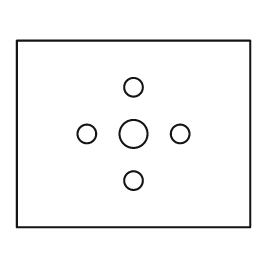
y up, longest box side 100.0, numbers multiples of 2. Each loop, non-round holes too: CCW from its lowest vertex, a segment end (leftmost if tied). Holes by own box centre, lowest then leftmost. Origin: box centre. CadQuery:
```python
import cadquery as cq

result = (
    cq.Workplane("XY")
    .moveTo(-50.0, -40.0)
    .lineTo(50.0, -40.0)
    .lineTo(50.0, 40.0)
    .lineTo(-50.0, 40.0)
    .close()
    .moveTo(0.0, -20.0)
    .circle(4.0)
    .moveTo(-20.0, 0.0)
    .circle(4.0)
    .moveTo(0.0, 0.0)
    .circle(6.0)
    .moveTo(20.0, 0.0)
    .circle(4.0)
    .moveTo(0.0, 20.0)
    .circle(4.0)
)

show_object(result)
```